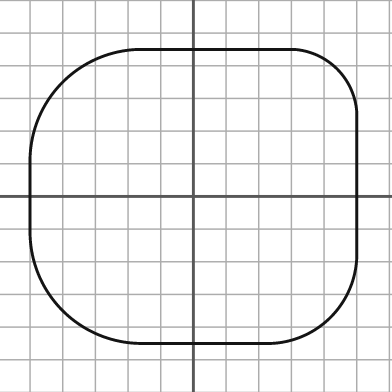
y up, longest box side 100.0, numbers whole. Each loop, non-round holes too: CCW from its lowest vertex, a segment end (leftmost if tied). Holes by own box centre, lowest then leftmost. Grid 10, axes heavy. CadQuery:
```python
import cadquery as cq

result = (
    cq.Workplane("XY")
    .moveTo(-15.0, -45.0)
    .lineTo(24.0, -45.0)
    .threePointArc((42.0, -37.0), (50.0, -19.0))
    .lineTo(50.0, 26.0)
    .threePointArc((44.0, 39.0), (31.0, 45.0))
    .lineTo(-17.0, 45.0)
    .threePointArc((-40.0, 35.0), (-50.0, 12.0))
    .lineTo(-50.0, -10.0)
    .threePointArc((-40.0, -35.0), (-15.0, -45.0))
    .close()
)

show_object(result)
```